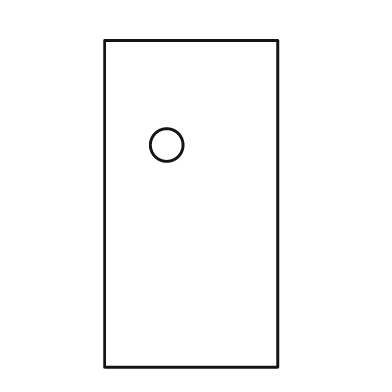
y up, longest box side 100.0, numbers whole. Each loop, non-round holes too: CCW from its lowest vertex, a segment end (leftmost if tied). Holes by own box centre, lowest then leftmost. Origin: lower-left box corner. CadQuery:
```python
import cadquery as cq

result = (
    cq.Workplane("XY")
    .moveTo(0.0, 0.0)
    .lineTo(53.0, 0.0)
    .lineTo(53.0, 100.0)
    .lineTo(0.0, 100.0)
    .close()
    .moveTo(19.0, 68.0)
    .circle(5.0)
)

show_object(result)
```